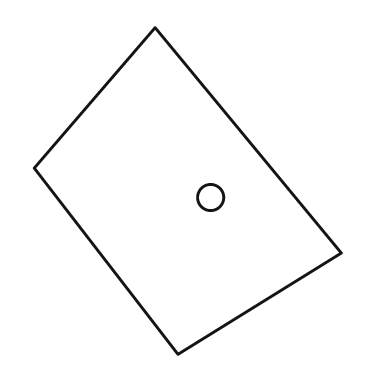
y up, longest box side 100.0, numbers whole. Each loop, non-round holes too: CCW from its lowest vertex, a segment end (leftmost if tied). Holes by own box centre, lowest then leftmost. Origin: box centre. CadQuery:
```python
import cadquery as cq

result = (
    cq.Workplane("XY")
    .moveTo(-3.0, -50.0)
    .lineTo(47.0, -19.0)
    .lineTo(-10.0, 50.0)
    .lineTo(-47.0, 7.0)
    .close()
    .moveTo(7.0, -2.0)
    .circle(4.0)
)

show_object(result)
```